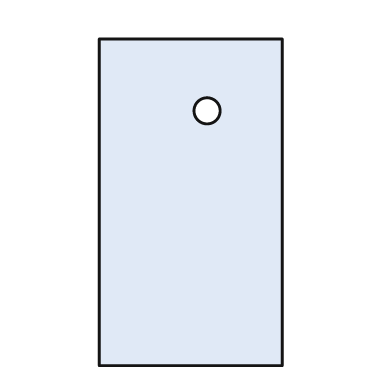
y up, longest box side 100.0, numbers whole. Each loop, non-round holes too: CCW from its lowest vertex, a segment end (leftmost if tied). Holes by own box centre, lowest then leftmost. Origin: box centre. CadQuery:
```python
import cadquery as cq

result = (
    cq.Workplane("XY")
    .moveTo(-28.0, -50.0)
    .lineTo(28.0, -50.0)
    .lineTo(28.0, 50.0)
    .lineTo(-28.0, 50.0)
    .close()
    .moveTo(5.0, 28.0)
    .circle(4.0)
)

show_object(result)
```